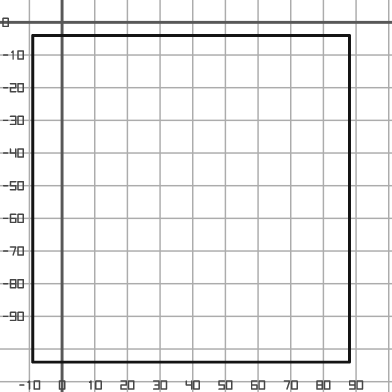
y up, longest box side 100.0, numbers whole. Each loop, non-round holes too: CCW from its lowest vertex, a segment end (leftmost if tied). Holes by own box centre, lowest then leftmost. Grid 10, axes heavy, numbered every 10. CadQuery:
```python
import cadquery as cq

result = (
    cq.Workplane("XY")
    .moveTo(-9.0, -104.0)
    .lineTo(88.0, -104.0)
    .lineTo(88.0, -4.0)
    .lineTo(-9.0, -4.0)
    .close()
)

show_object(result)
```